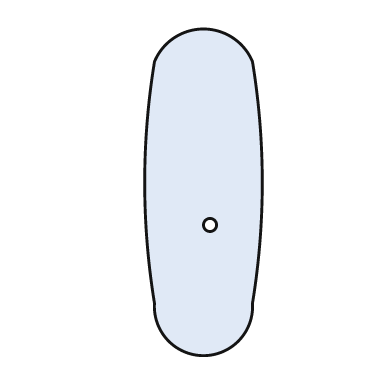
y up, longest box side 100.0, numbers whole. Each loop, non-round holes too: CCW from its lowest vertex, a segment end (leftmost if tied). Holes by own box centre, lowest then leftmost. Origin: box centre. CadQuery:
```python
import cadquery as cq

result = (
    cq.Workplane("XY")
    .moveTo(-15.0, -34.0)
    .threePointArc((0.0, -50.0), (15.0, -34.0))
    .threePointArc((18.0, 3.0), (15.0, 40.0))
    .threePointArc((0.0, 50.0), (-15.0, 40.0))
    .threePointArc((-18.0, 3.0), (-15.0, -34.0))
    .close()
    .moveTo(2.0, -10.0)
    .circle(2.0)
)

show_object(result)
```